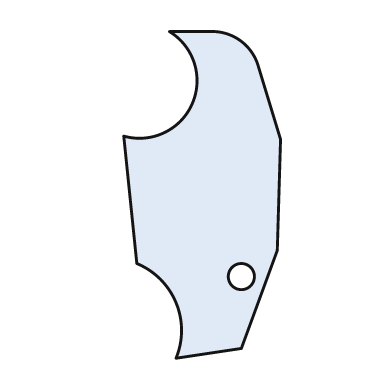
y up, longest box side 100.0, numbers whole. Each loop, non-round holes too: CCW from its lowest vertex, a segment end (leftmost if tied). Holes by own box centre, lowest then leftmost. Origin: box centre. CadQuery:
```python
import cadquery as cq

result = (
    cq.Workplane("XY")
    .moveTo(-8.0, -50.0)
    .lineTo(12.0, -47.0)
    .lineTo(23.0, -17.0)
    .lineTo(24.0, 17.0)
    .lineTo(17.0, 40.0)
    .threePointArc((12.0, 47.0), (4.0, 50.0))
    .lineTo(-10.0, 50.0)
    .threePointArc((-3.0, 28.0), (-24.0, 18.0))
    .lineTo(-20.0, -21.0)
    .threePointArc((-8.0, -33.0), (-8.0, -50.0))
    .close()
    .moveTo(12.0, -25.0)
    .circle(4.0)
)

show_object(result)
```